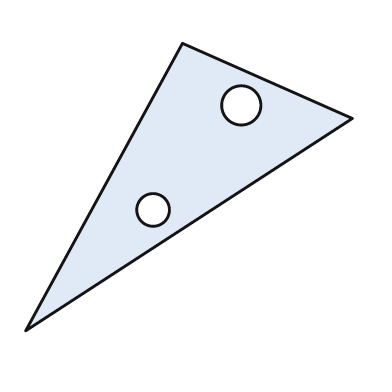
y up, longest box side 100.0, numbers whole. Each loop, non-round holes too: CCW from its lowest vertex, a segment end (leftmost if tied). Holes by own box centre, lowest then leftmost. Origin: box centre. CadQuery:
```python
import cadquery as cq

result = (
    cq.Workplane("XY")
    .moveTo(-50.0, -44.0)
    .lineTo(50.0, 21.0)
    .lineTo(-2.0, 44.0)
    .close()
    .moveTo(-11.0, -7.0)
    .circle(5.0)
    .moveTo(16.0, 25.0)
    .circle(6.0)
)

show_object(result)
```